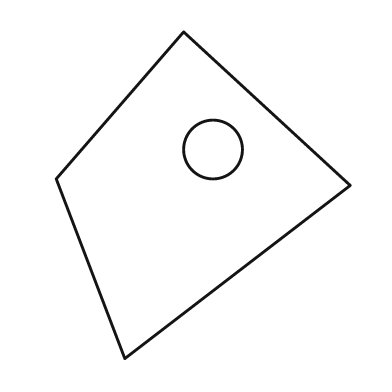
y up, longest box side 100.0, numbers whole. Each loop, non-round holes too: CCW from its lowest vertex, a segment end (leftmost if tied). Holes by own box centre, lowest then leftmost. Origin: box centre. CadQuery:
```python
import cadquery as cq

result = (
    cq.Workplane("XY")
    .moveTo(-24.0, -50.0)
    .lineTo(45.0, 3.0)
    .lineTo(-6.0, 50.0)
    .lineTo(-45.0, 5.0)
    .close()
    .moveTo(3.0, 14.0)
    .circle(9.0)
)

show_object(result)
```